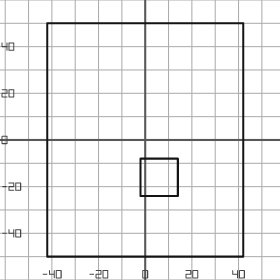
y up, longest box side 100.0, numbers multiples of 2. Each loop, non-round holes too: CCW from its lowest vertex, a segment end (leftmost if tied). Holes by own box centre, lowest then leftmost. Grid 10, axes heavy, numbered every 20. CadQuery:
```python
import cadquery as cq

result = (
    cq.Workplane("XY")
    .moveTo(-42.0, -50.0)
    .lineTo(42.0, -50.0)
    .lineTo(42.0, 50.0)
    .lineTo(-42.0, 50.0)
    .close()
    .moveTo(-2.0, -24.0)
    .lineTo(14.0, -24.0)
    .lineTo(14.0, -8.0)
    .lineTo(-2.0, -8.0)
    .close()
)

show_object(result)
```